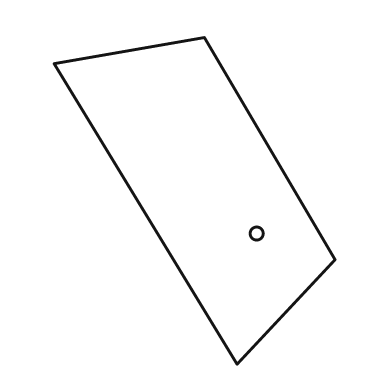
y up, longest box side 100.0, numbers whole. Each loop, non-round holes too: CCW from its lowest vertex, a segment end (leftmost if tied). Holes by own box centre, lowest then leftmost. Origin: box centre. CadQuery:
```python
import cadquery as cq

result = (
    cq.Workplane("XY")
    .moveTo(13.0, -50.0)
    .lineTo(43.0, -18.0)
    .lineTo(3.0, 50.0)
    .lineTo(-43.0, 42.0)
    .close()
    .moveTo(19.0, -10.0)
    .circle(2.0)
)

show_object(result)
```